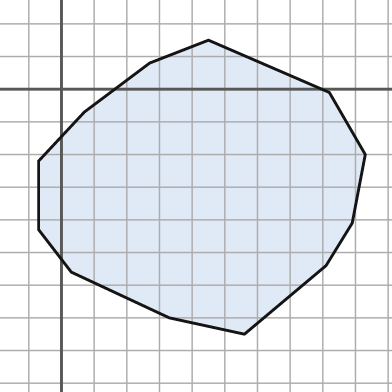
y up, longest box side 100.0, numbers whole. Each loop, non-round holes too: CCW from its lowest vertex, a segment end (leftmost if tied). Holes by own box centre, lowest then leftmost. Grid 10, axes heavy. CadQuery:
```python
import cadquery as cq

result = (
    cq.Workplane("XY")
    .moveTo(56.0, -75.0)
    .lineTo(81.0, -54.0)
    .lineTo(89.0, -41.0)
    .lineTo(93.0, -20.0)
    .lineTo(82.0, -1.0)
    .lineTo(45.0, 15.0)
    .lineTo(27.0, 8.0)
    .lineTo(7.0, -7.0)
    .lineTo(-7.0, -22.0)
    .lineTo(-7.0, -43.0)
    .lineTo(3.0, -56.0)
    .lineTo(33.0, -70.0)
    .close()
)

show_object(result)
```